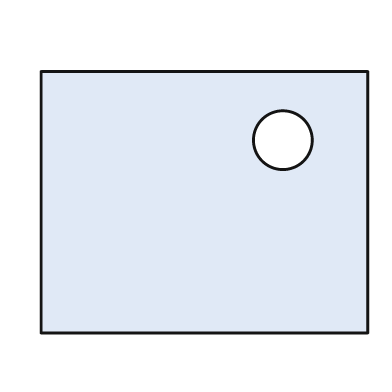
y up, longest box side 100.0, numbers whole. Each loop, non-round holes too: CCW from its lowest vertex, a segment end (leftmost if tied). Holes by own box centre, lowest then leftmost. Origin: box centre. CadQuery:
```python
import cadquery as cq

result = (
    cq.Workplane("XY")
    .moveTo(-50.0, -40.0)
    .lineTo(50.0, -40.0)
    .lineTo(50.0, 40.0)
    .lineTo(-50.0, 40.0)
    .close()
    .moveTo(24.0, 19.0)
    .circle(9.0)
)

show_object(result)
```